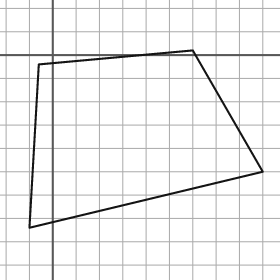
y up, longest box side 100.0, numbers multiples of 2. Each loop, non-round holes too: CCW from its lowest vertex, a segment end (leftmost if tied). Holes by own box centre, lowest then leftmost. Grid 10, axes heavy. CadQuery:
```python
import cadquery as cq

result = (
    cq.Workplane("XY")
    .moveTo(-10.0, -74.0)
    .lineTo(90.0, -50.0)
    .lineTo(60.0, 2.0)
    .lineTo(-6.0, -4.0)
    .close()
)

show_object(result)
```